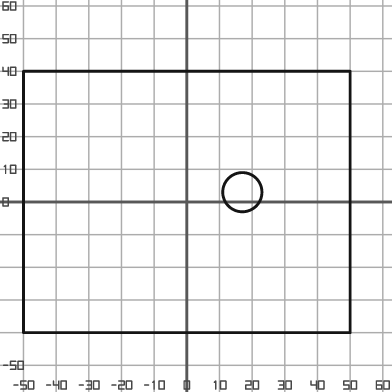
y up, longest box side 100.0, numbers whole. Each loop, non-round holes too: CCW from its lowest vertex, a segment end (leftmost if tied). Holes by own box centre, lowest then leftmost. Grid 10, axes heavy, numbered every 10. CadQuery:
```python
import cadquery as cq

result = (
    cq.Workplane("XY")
    .moveTo(-50.0, -40.0)
    .lineTo(50.0, -40.0)
    .lineTo(50.0, 40.0)
    .lineTo(-50.0, 40.0)
    .close()
    .moveTo(17.0, 3.0)
    .circle(6.0)
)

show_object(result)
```